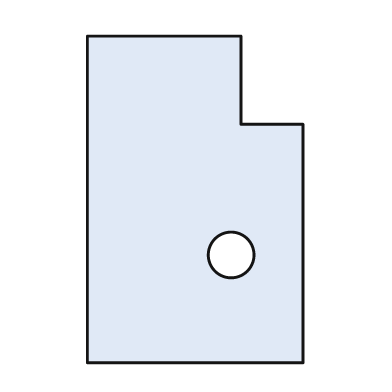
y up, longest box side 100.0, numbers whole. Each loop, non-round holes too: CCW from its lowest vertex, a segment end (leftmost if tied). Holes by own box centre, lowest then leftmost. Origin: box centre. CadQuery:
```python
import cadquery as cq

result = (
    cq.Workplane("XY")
    .moveTo(-33.0, -50.0)
    .lineTo(33.0, -50.0)
    .lineTo(33.0, 23.0)
    .lineTo(14.0, 23.0)
    .lineTo(14.0, 50.0)
    .lineTo(-33.0, 50.0)
    .close()
    .moveTo(11.0, -17.0)
    .circle(7.0)
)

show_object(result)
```